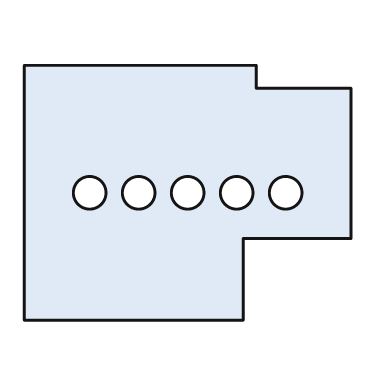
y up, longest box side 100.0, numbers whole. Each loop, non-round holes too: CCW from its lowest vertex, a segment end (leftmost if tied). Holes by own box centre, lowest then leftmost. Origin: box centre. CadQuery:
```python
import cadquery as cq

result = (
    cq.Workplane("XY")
    .moveTo(-50.0, -39.0)
    .lineTo(17.0, -39.0)
    .lineTo(17.0, -14.0)
    .lineTo(50.0, -14.0)
    .lineTo(50.0, 32.0)
    .lineTo(21.0, 32.0)
    .lineTo(21.0, 39.0)
    .lineTo(-50.0, 39.0)
    .close()
    .moveTo(-30.0, 0.0)
    .circle(5.0)
    .moveTo(-15.0, 0.0)
    .circle(5.0)
    .moveTo(0.0, 0.0)
    .circle(5.0)
    .moveTo(15.0, 0.0)
    .circle(5.0)
    .moveTo(30.0, 0.0)
    .circle(5.0)
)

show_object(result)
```